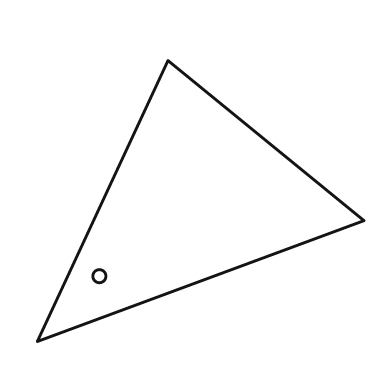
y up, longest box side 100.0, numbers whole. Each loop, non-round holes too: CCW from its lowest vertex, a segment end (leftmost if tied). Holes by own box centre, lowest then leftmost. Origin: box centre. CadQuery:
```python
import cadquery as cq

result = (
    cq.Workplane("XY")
    .moveTo(-50.0, -43.0)
    .lineTo(50.0, -6.0)
    .lineTo(-10.0, 43.0)
    .close()
    .moveTo(-31.0, -23.0)
    .circle(2.0)
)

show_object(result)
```